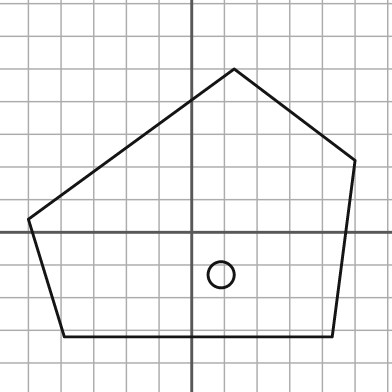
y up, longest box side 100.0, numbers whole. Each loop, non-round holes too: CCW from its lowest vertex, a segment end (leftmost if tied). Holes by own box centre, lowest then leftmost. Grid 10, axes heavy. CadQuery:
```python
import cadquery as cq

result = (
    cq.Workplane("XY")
    .moveTo(-39.0, -32.0)
    .lineTo(43.0, -32.0)
    .lineTo(50.0, 22.0)
    .lineTo(13.0, 50.0)
    .lineTo(-50.0, 4.0)
    .close()
    .moveTo(9.0, -13.0)
    .circle(4.0)
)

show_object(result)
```